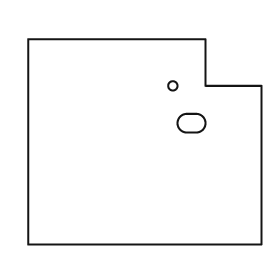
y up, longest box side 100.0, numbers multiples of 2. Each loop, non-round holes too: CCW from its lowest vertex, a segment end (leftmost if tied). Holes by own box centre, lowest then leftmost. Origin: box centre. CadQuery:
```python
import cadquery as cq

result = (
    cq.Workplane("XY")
    .moveTo(-50.0, -44.0)
    .lineTo(50.0, -44.0)
    .lineTo(50.0, 24.0)
    .lineTo(26.0, 24.0)
    .lineTo(26.0, 44.0)
    .lineTo(-50.0, 44.0)
    .close()
    .moveTo(18.0, 4.0)
    .lineTo(22.0, 4.0)
    .threePointArc((26.0, 8.0), (22.0, 12.0))
    .lineTo(18.0, 12.0)
    .threePointArc((14.0, 8.0), (18.0, 4.0))
    .close()
    .moveTo(12.0, 24.0)
    .circle(2.0)
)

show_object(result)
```